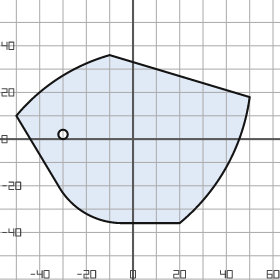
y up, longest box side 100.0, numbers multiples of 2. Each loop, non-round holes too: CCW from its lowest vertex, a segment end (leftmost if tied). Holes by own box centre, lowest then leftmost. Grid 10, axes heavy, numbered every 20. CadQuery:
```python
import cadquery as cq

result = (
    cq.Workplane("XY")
    .moveTo(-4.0, -36.0)
    .lineTo(20.0, -36.0)
    .threePointArc((40.0, -12.0), (50.0, 18.0))
    .lineTo(-10.0, 36.0)
    .threePointArc((-32.0, 26.0), (-50.0, 10.0))
    .lineTo(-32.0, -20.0)
    .threePointArc((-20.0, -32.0), (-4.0, -36.0))
    .close()
    .moveTo(-30.0, 2.0)
    .circle(2.0)
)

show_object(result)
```